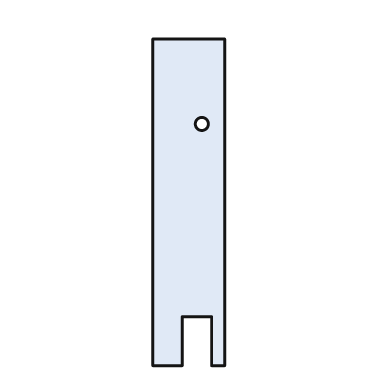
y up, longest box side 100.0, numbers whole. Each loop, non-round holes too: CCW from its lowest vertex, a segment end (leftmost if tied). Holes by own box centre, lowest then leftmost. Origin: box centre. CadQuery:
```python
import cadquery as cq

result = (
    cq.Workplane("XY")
    .moveTo(-11.0, -50.0)
    .lineTo(-2.0, -50.0)
    .lineTo(-2.0, -35.0)
    .lineTo(7.0, -35.0)
    .lineTo(7.0, -50.0)
    .lineTo(11.0, -50.0)
    .lineTo(11.0, 50.0)
    .lineTo(-11.0, 50.0)
    .close()
    .moveTo(4.0, 24.0)
    .circle(2.0)
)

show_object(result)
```